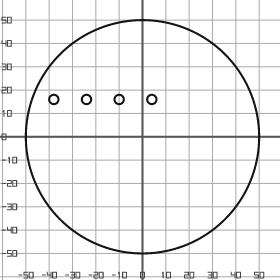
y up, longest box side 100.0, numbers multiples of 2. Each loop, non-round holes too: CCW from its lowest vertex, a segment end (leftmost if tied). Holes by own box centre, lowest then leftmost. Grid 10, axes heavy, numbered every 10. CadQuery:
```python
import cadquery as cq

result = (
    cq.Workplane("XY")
    .moveTo(0.0, 0.0)
    .circle(50.0)
    .moveTo(-38.0, 16.0)
    .circle(2.0)
    .moveTo(-24.0, 16.0)
    .circle(2.0)
    .moveTo(-10.0, 16.0)
    .circle(2.0)
    .moveTo(4.0, 16.0)
    .circle(2.0)
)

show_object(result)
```